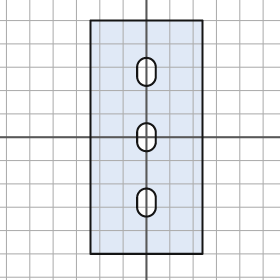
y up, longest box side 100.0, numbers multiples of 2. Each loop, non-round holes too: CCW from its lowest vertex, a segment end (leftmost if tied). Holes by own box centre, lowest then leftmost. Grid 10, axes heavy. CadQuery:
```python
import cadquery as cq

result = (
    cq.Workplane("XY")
    .moveTo(-24.0, -50.0)
    .lineTo(24.0, -50.0)
    .lineTo(24.0, 50.0)
    .lineTo(-24.0, 50.0)
    .close()
    .moveTo(-4.0, -30.0)
    .threePointArc((0.0, -34.0), (4.0, -30.0))
    .lineTo(4.0, -26.0)
    .threePointArc((0.0, -22.0), (-4.0, -26.0))
    .close()
    .moveTo(-4.0, -2.0)
    .threePointArc((0.0, -6.0), (4.0, -2.0))
    .lineTo(4.0, 2.0)
    .threePointArc((0.0, 6.0), (-4.0, 2.0))
    .close()
    .moveTo(-4.0, 26.0)
    .threePointArc((0.0, 22.0), (4.0, 26.0))
    .lineTo(4.0, 30.0)
    .threePointArc((0.0, 34.0), (-4.0, 30.0))
    .close()
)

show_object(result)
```